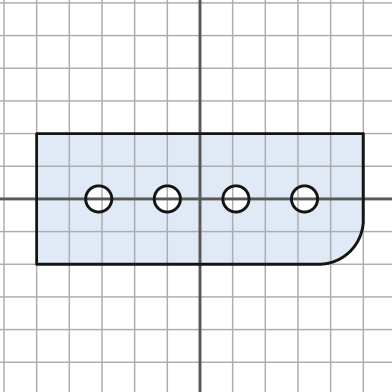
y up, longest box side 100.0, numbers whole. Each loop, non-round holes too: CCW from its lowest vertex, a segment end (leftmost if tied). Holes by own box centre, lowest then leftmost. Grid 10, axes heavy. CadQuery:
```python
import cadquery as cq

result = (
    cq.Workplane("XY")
    .moveTo(-50.0, -20.0)
    .lineTo(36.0, -20.0)
    .threePointArc((46.0, -16.0), (50.0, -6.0))
    .lineTo(50.0, 20.0)
    .lineTo(-50.0, 20.0)
    .close()
    .moveTo(-31.0, 0.0)
    .circle(4.0)
    .moveTo(-10.0, 0.0)
    .circle(4.0)
    .moveTo(11.0, 0.0)
    .circle(4.0)
    .moveTo(32.0, 0.0)
    .circle(4.0)
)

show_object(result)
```